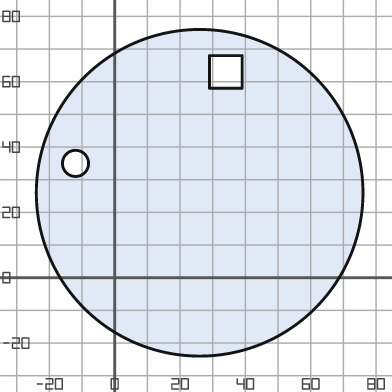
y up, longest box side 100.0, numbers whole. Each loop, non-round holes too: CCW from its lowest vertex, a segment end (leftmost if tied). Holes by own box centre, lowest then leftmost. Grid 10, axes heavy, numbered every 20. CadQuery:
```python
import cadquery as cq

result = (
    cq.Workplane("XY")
    .moveTo(26.0, 26.0)
    .circle(50.0)
    .moveTo(-12.0, 35.0)
    .circle(4.0)
    .moveTo(29.0, 58.0)
    .lineTo(39.0, 58.0)
    .lineTo(39.0, 68.0)
    .lineTo(29.0, 68.0)
    .close()
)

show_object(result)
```